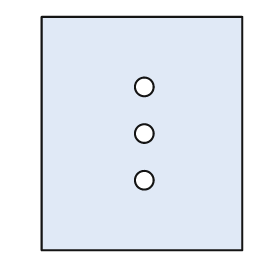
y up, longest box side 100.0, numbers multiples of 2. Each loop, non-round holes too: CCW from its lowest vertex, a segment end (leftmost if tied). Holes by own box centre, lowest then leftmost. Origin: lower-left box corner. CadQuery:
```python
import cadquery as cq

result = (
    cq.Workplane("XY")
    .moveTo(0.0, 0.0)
    .lineTo(86.0, 0.0)
    .lineTo(86.0, 100.0)
    .lineTo(0.0, 100.0)
    .close()
    .moveTo(44.0, 30.0)
    .circle(4.0)
    .moveTo(44.0, 50.0)
    .circle(4.0)
    .moveTo(44.0, 70.0)
    .circle(4.0)
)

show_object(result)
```